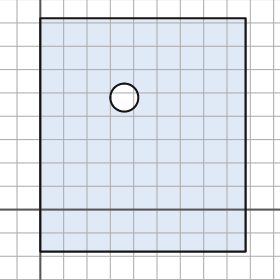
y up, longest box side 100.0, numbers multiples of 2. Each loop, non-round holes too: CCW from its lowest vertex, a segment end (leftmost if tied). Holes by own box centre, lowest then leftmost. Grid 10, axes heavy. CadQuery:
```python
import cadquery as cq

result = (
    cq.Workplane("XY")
    .moveTo(0.0, -18.0)
    .lineTo(88.0, -18.0)
    .lineTo(88.0, 82.0)
    .lineTo(0.0, 82.0)
    .close()
    .moveTo(36.0, 48.0)
    .circle(6.0)
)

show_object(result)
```